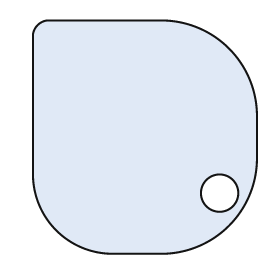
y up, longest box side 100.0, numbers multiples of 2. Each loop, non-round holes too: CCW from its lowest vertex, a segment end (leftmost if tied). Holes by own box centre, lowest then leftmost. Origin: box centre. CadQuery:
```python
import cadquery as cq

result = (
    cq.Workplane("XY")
    .moveTo(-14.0, -50.0)
    .lineTo(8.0, -50.0)
    .threePointArc((36.0, -38.0), (48.0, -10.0))
    .lineTo(48.0, 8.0)
    .threePointArc((36.0, 38.0), (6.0, 50.0))
    .lineTo(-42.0, 50.0)
    .threePointArc((-46.0, 48.0), (-48.0, 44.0))
    .lineTo(-48.0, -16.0)
    .threePointArc((-38.0, -40.0), (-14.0, -50.0))
    .close()
    .moveTo(32.0, -24.0)
    .circle(8.0)
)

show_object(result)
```